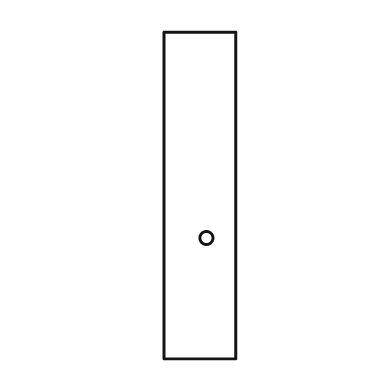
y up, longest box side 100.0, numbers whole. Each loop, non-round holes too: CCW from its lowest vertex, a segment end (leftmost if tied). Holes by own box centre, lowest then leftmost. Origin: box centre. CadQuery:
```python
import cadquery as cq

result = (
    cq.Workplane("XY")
    .moveTo(-11.0, -50.0)
    .lineTo(11.0, -50.0)
    .lineTo(11.0, 50.0)
    .lineTo(-11.0, 50.0)
    .close()
    .moveTo(2.0, -13.0)
    .circle(2.0)
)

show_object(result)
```